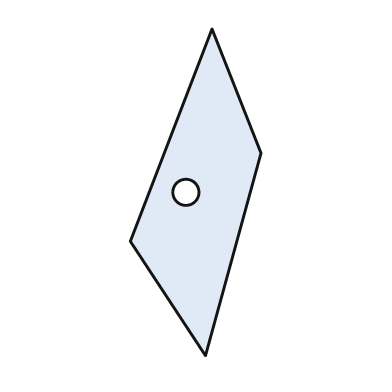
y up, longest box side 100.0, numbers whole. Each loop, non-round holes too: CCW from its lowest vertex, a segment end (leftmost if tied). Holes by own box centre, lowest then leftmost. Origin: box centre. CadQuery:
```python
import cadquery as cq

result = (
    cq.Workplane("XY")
    .moveTo(3.0, -50.0)
    .lineTo(20.0, 12.0)
    .lineTo(5.0, 50.0)
    .lineTo(-20.0, -15.0)
    .close()
    .moveTo(-3.0, 0.0)
    .circle(4.0)
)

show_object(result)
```